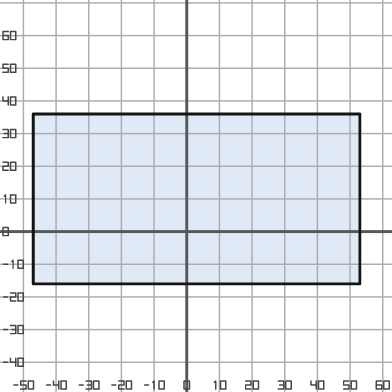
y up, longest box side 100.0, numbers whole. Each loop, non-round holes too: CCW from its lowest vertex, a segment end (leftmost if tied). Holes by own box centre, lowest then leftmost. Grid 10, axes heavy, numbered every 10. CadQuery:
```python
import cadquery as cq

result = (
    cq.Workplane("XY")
    .moveTo(-47.0, -16.0)
    .lineTo(53.0, -16.0)
    .lineTo(53.0, 36.0)
    .lineTo(-47.0, 36.0)
    .close()
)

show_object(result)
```